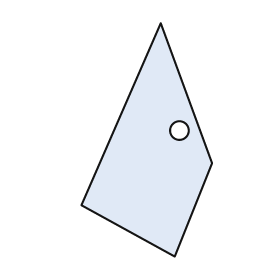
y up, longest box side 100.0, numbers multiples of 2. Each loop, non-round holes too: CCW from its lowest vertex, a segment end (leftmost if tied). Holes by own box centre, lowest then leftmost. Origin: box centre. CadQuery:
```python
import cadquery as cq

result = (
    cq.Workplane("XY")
    .moveTo(12.0, -50.0)
    .lineTo(28.0, -10.0)
    .lineTo(6.0, 50.0)
    .lineTo(-28.0, -28.0)
    .close()
    .moveTo(14.0, 4.0)
    .circle(4.0)
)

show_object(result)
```